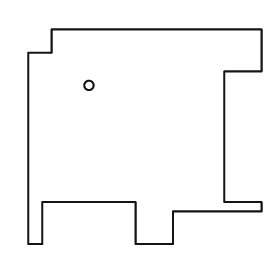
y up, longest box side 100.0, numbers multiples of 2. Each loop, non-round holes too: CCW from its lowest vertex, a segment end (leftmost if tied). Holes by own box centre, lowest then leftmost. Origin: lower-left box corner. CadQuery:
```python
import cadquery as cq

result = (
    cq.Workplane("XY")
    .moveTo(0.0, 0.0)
    .lineTo(6.0, 0.0)
    .lineTo(6.0, 18.0)
    .lineTo(46.0, 18.0)
    .lineTo(46.0, 0.0)
    .lineTo(62.0, 0.0)
    .lineTo(62.0, 14.0)
    .lineTo(100.0, 14.0)
    .lineTo(100.0, 18.0)
    .lineTo(84.0, 18.0)
    .lineTo(84.0, 74.0)
    .lineTo(100.0, 74.0)
    .lineTo(100.0, 92.0)
    .lineTo(10.0, 92.0)
    .lineTo(10.0, 82.0)
    .lineTo(0.0, 82.0)
    .close()
    .moveTo(26.0, 68.0)
    .circle(2.0)
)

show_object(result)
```